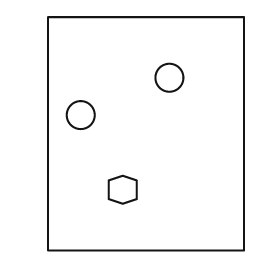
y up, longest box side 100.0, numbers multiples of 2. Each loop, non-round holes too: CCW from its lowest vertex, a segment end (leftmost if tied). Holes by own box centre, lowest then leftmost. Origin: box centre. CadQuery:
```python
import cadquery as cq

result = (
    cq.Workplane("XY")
    .moveTo(-42.0, -50.0)
    .lineTo(42.0, -50.0)
    .lineTo(42.0, 50.0)
    .lineTo(-42.0, 50.0)
    .close()
    .moveTo(-10.0, -30.0)
    .lineTo(-4.0, -28.0)
    .lineTo(-4.0, -20.0)
    .lineTo(-10.0, -18.0)
    .lineTo(-16.0, -20.0)
    .lineTo(-16.0, -28.0)
    .close()
    .moveTo(-28.0, 8.0)
    .circle(6.0)
    .moveTo(10.0, 24.0)
    .circle(6.0)
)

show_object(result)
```